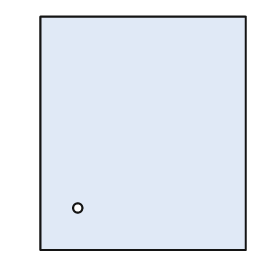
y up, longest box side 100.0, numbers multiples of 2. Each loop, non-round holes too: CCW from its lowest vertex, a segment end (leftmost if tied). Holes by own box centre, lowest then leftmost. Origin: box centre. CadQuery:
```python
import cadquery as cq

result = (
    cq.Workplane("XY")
    .moveTo(-44.0, -50.0)
    .lineTo(44.0, -50.0)
    .lineTo(44.0, 50.0)
    .lineTo(-44.0, 50.0)
    .close()
    .moveTo(-28.0, -32.0)
    .circle(2.0)
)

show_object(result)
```